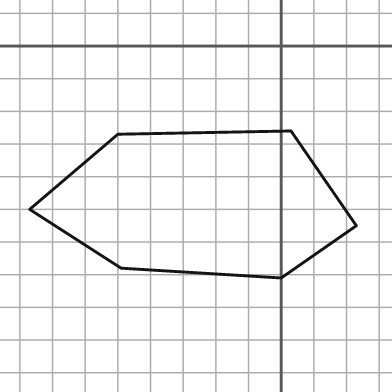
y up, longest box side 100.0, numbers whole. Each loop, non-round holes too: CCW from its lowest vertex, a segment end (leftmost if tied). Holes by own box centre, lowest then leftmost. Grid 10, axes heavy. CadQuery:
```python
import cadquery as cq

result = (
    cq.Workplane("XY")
    .moveTo(0.0, -71.0)
    .lineTo(23.0, -55.0)
    .lineTo(3.0, -26.0)
    .lineTo(-50.0, -27.0)
    .lineTo(-77.0, -50.0)
    .lineTo(-49.0, -68.0)
    .close()
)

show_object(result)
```